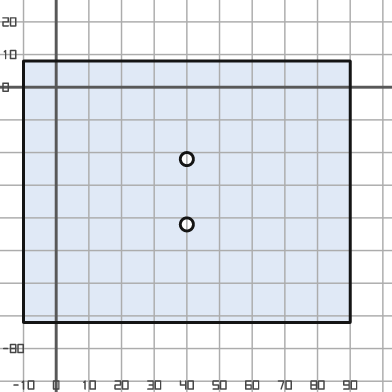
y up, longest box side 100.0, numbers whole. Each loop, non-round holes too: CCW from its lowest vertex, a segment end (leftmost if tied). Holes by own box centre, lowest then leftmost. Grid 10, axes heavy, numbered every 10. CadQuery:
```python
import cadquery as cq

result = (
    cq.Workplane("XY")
    .moveTo(-10.0, -72.0)
    .lineTo(90.0, -72.0)
    .lineTo(90.0, 8.0)
    .lineTo(-10.0, 8.0)
    .close()
    .moveTo(40.0, -42.0)
    .circle(2.0)
    .moveTo(40.0, -22.0)
    .circle(2.0)
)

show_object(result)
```